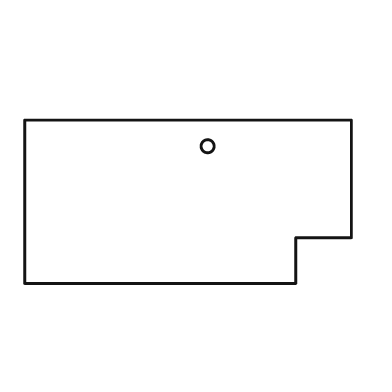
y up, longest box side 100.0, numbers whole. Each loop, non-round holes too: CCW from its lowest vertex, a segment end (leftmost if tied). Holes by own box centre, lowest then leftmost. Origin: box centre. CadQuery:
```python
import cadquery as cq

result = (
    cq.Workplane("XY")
    .moveTo(-50.0, -25.0)
    .lineTo(33.0, -25.0)
    .lineTo(33.0, -11.0)
    .lineTo(50.0, -11.0)
    .lineTo(50.0, 25.0)
    .lineTo(-50.0, 25.0)
    .close()
    .moveTo(6.0, 17.0)
    .circle(2.0)
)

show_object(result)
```